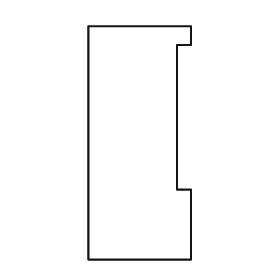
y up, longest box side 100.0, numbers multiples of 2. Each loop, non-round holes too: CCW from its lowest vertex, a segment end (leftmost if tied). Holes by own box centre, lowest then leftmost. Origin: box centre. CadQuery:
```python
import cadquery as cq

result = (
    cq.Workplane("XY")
    .moveTo(-22.0, -50.0)
    .lineTo(22.0, -50.0)
    .lineTo(22.0, -20.0)
    .lineTo(16.0, -20.0)
    .lineTo(16.0, 42.0)
    .lineTo(22.0, 42.0)
    .lineTo(22.0, 50.0)
    .lineTo(-22.0, 50.0)
    .close()
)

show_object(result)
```